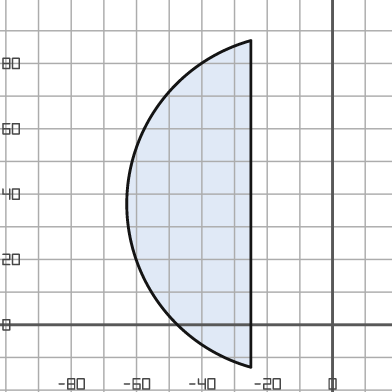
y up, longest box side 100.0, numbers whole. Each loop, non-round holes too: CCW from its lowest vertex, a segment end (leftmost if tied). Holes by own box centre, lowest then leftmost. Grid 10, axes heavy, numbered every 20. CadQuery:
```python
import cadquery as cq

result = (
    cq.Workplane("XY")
    .moveTo(-25.0, -13.0)
    .lineTo(-25.0, 87.0)
    .threePointArc((-63.0, 37.0), (-25.0, -13.0))
    .close()
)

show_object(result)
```